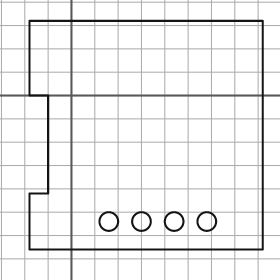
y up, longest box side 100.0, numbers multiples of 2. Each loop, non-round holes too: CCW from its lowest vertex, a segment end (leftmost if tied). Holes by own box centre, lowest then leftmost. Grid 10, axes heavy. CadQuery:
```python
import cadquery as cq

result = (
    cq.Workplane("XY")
    .moveTo(-18.0, -66.0)
    .lineTo(82.0, -66.0)
    .lineTo(82.0, 32.0)
    .lineTo(-18.0, 32.0)
    .lineTo(-18.0, 0.0)
    .lineTo(-10.0, 0.0)
    .lineTo(-10.0, -42.0)
    .lineTo(-18.0, -42.0)
    .close()
    .moveTo(16.0, -54.0)
    .circle(4.0)
    .moveTo(30.0, -54.0)
    .circle(4.0)
    .moveTo(44.0, -54.0)
    .circle(4.0)
    .moveTo(58.0, -54.0)
    .circle(4.0)
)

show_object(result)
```